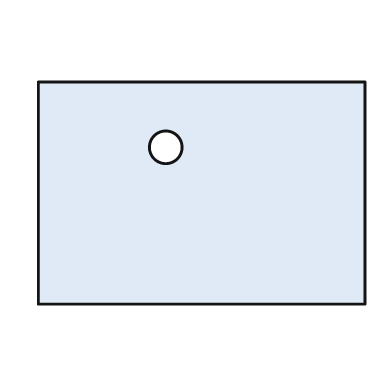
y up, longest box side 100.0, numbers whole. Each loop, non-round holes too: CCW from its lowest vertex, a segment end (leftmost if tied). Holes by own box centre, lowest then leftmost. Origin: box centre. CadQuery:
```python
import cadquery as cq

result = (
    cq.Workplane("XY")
    .moveTo(-50.0, -34.0)
    .lineTo(50.0, -34.0)
    .lineTo(50.0, 34.0)
    .lineTo(-50.0, 34.0)
    .close()
    .moveTo(-11.0, 14.0)
    .circle(5.0)
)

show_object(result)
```